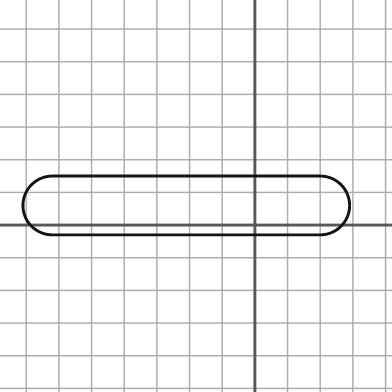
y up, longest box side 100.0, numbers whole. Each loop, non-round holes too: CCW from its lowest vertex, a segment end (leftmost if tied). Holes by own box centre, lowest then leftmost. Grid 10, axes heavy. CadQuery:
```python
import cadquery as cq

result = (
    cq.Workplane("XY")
    .moveTo(-62.0, -3.0)
    .lineTo(20.0, -3.0)
    .threePointArc((29.0, 6.0), (20.0, 15.0))
    .lineTo(-62.0, 15.0)
    .threePointArc((-71.0, 6.0), (-62.0, -3.0))
    .close()
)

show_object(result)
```